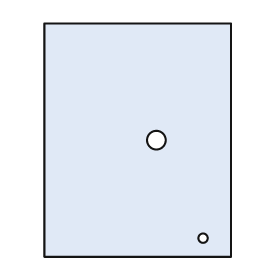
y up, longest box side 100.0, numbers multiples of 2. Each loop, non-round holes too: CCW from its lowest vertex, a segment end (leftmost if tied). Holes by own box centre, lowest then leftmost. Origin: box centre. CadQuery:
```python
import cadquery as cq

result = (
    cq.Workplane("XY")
    .moveTo(-40.0, -50.0)
    .lineTo(40.0, -50.0)
    .lineTo(40.0, 50.0)
    .lineTo(-40.0, 50.0)
    .close()
    .moveTo(28.0, -42.0)
    .circle(2.0)
    .moveTo(8.0, 0.0)
    .circle(4.0)
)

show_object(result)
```